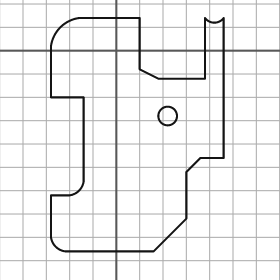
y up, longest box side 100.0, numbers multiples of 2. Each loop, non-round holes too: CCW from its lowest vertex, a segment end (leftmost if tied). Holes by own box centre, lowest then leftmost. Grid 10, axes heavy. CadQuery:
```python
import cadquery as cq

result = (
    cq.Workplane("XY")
    .moveTo(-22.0, -86.0)
    .lineTo(16.0, -86.0)
    .lineTo(30.0, -72.0)
    .lineTo(30.0, -52.0)
    .lineTo(36.0, -46.0)
    .lineTo(46.0, -46.0)
    .lineTo(46.0, 14.0)
    .threePointArc((42.0, 12.0), (38.0, 14.0))
    .lineTo(38.0, -12.0)
    .lineTo(18.0, -12.0)
    .lineTo(10.0, -8.0)
    .lineTo(10.0, 14.0)
    .lineTo(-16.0, 14.0)
    .threePointArc((-24.0, 10.0), (-28.0, 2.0))
    .lineTo(-28.0, -20.0)
    .lineTo(-14.0, -20.0)
    .lineTo(-14.0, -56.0)
    .threePointArc((-16.0, -60.0), (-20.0, -62.0))
    .lineTo(-28.0, -62.0)
    .lineTo(-28.0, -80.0)
    .threePointArc((-26.0, -84.0), (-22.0, -86.0))
    .close()
    .moveTo(22.0, -28.0)
    .circle(4.0)
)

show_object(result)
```